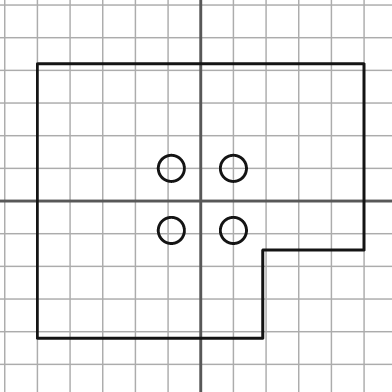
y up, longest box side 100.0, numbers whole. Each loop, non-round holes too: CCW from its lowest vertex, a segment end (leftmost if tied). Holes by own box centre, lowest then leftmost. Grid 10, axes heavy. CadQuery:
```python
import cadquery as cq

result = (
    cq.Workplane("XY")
    .moveTo(-50.0, -42.0)
    .lineTo(19.0, -42.0)
    .lineTo(19.0, -15.0)
    .lineTo(50.0, -15.0)
    .lineTo(50.0, 42.0)
    .lineTo(-50.0, 42.0)
    .close()
    .moveTo(-9.0, -9.0)
    .circle(4.0)
    .moveTo(10.0, -9.0)
    .circle(4.0)
    .moveTo(-9.0, 10.0)
    .circle(4.0)
    .moveTo(10.0, 10.0)
    .circle(4.0)
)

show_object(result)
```